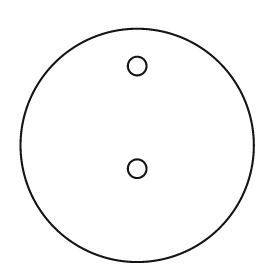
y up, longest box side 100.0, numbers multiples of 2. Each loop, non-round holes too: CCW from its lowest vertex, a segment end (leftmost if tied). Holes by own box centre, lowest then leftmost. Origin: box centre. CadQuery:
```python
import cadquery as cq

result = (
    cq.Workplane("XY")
    .moveTo(0.0, 0.0)
    .circle(50.0)
    .moveTo(0.0, -10.0)
    .circle(4.0)
    .moveTo(0.0, 34.0)
    .circle(4.0)
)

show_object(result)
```